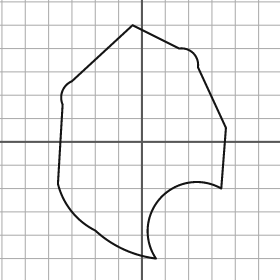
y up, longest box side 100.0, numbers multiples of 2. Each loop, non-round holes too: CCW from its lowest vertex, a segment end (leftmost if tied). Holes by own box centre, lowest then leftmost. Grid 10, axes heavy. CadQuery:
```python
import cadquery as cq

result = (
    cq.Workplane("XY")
    .moveTo(6.0, -50.0)
    .threePointArc((8.0, -24.0), (34.0, -20.0))
    .lineTo(36.0, 6.0)
    .lineTo(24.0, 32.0)
    .threePointArc((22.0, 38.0), (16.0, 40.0))
    .lineTo(-4.0, 50.0)
    .lineTo(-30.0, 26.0)
    .threePointArc((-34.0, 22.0), (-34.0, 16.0))
    .lineTo(-36.0, -18.0)
    .threePointArc((-30.0, -30.0), (-20.0, -38.0))
    .threePointArc((-8.0, -46.0), (6.0, -50.0))
    .close()
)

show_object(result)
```